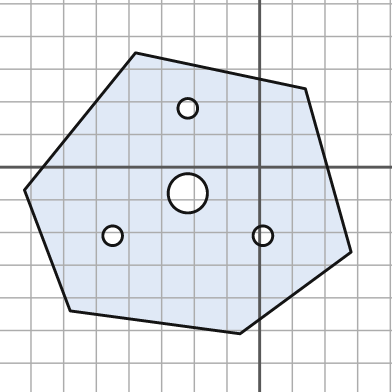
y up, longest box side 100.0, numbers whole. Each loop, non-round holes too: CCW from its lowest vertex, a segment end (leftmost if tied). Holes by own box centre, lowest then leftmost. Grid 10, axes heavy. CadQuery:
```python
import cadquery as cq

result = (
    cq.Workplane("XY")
    .moveTo(-6.0, -51.0)
    .lineTo(28.0, -26.0)
    .lineTo(14.0, 24.0)
    .lineTo(-38.0, 35.0)
    .lineTo(-72.0, -7.0)
    .lineTo(-58.0, -44.0)
    .close()
    .moveTo(-45.0, -21.0)
    .circle(3.0)
    .moveTo(1.0, -21.0)
    .circle(3.0)
    .moveTo(-22.0, -8.0)
    .circle(6.0)
    .moveTo(-22.0, 18.0)
    .circle(3.0)
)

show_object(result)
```